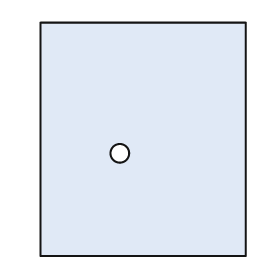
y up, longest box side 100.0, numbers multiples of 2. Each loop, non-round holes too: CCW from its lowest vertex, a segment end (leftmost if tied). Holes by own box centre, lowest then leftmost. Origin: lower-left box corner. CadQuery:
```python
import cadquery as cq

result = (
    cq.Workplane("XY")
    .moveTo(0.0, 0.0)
    .lineTo(88.0, 0.0)
    .lineTo(88.0, 100.0)
    .lineTo(0.0, 100.0)
    .close()
    .moveTo(34.0, 44.0)
    .circle(4.0)
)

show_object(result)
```